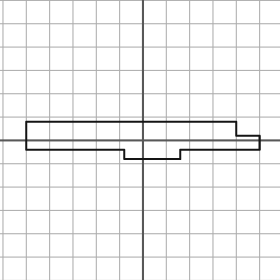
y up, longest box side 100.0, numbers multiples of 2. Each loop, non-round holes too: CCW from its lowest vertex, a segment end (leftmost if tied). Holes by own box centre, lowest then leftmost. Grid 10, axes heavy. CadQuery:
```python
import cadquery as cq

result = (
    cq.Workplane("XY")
    .moveTo(-8.0, -8.0)
    .lineTo(16.0, -8.0)
    .lineTo(16.0, -4.0)
    .lineTo(50.0, -4.0)
    .lineTo(50.0, 2.0)
    .lineTo(40.0, 2.0)
    .lineTo(40.0, 8.0)
    .lineTo(-50.0, 8.0)
    .lineTo(-50.0, -4.0)
    .lineTo(-8.0, -4.0)
    .close()
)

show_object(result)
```